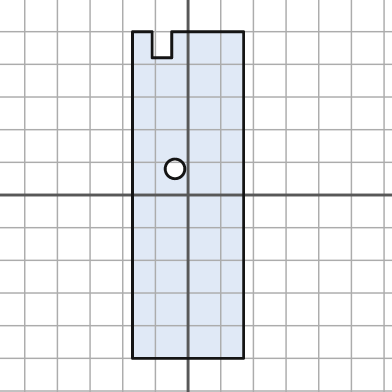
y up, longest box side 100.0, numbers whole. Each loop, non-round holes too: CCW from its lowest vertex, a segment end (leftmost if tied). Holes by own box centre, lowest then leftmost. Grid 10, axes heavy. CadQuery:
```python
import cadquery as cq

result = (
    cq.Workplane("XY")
    .moveTo(-17.0, -50.0)
    .lineTo(17.0, -50.0)
    .lineTo(17.0, 50.0)
    .lineTo(-5.0, 50.0)
    .lineTo(-5.0, 42.0)
    .lineTo(-11.0, 42.0)
    .lineTo(-11.0, 50.0)
    .lineTo(-17.0, 50.0)
    .close()
    .moveTo(-4.0, 8.0)
    .circle(3.0)
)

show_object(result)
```